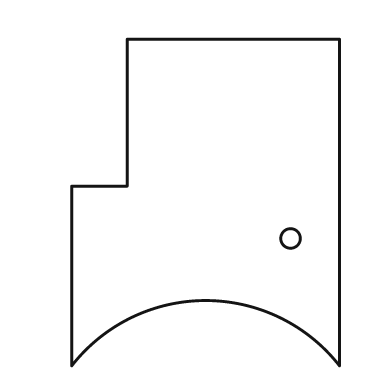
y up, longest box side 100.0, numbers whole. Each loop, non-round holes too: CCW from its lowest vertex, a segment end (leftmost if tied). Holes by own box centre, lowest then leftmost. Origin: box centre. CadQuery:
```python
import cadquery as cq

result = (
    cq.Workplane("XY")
    .moveTo(-41.0, -50.0)
    .threePointArc((0.0, -30.0), (41.0, -50.0))
    .lineTo(41.0, 50.0)
    .lineTo(-24.0, 50.0)
    .lineTo(-24.0, 5.0)
    .lineTo(-41.0, 5.0)
    .close()
    .moveTo(26.0, -11.0)
    .circle(3.0)
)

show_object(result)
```